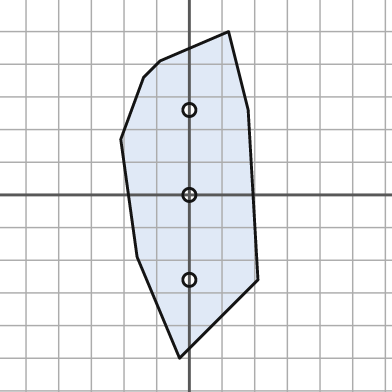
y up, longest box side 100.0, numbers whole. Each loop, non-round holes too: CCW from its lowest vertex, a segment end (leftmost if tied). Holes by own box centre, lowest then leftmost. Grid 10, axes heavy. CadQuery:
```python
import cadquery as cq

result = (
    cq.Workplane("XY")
    .moveTo(-3.0, -50.0)
    .lineTo(21.0, -26.0)
    .lineTo(18.0, 26.0)
    .lineTo(12.0, 50.0)
    .lineTo(-9.0, 41.0)
    .lineTo(-14.0, 36.0)
    .lineTo(-21.0, 17.0)
    .lineTo(-16.0, -19.0)
    .close()
    .moveTo(0.0, -26.0)
    .circle(2.0)
    .moveTo(0.0, 0.0)
    .circle(2.0)
    .moveTo(0.0, 26.0)
    .circle(2.0)
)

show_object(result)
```